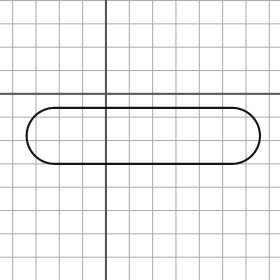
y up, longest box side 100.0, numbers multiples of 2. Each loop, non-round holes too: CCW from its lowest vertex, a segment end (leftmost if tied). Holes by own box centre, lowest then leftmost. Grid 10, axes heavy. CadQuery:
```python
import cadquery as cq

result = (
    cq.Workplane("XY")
    .moveTo(-22.0, -30.0)
    .lineTo(54.0, -30.0)
    .threePointArc((66.0, -18.0), (54.0, -6.0))
    .lineTo(-22.0, -6.0)
    .threePointArc((-34.0, -18.0), (-22.0, -30.0))
    .close()
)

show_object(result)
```